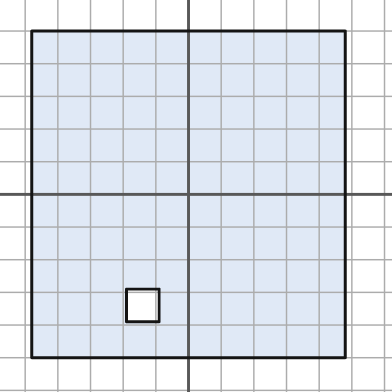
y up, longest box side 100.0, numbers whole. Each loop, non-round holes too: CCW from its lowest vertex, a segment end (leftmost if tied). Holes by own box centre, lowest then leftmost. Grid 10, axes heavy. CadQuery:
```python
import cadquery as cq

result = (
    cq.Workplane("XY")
    .moveTo(-48.0, -50.0)
    .lineTo(48.0, -50.0)
    .lineTo(48.0, 50.0)
    .lineTo(-48.0, 50.0)
    .close()
    .moveTo(-19.0, -39.0)
    .lineTo(-9.0, -39.0)
    .lineTo(-9.0, -29.0)
    .lineTo(-19.0, -29.0)
    .close()
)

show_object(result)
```